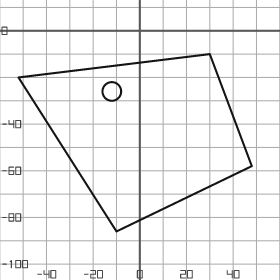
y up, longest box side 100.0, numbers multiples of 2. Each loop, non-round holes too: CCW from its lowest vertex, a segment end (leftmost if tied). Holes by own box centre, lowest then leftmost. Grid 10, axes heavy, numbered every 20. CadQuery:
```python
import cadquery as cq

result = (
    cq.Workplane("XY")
    .moveTo(-10.0, -86.0)
    .lineTo(48.0, -58.0)
    .lineTo(30.0, -10.0)
    .lineTo(-52.0, -20.0)
    .close()
    .moveTo(-12.0, -26.0)
    .circle(4.0)
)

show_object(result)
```